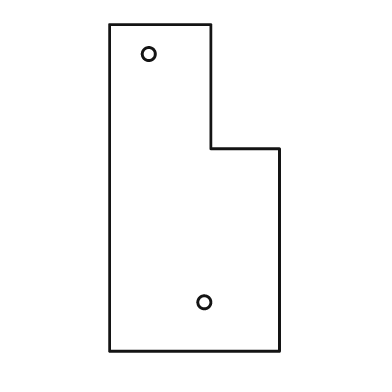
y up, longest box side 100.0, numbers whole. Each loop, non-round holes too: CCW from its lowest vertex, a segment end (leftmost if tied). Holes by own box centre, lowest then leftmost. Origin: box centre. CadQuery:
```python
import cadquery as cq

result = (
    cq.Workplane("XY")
    .moveTo(-26.0, -50.0)
    .lineTo(26.0, -50.0)
    .lineTo(26.0, 12.0)
    .lineTo(5.0, 12.0)
    .lineTo(5.0, 50.0)
    .lineTo(-26.0, 50.0)
    .close()
    .moveTo(3.0, -35.0)
    .circle(2.0)
    .moveTo(-14.0, 41.0)
    .circle(2.0)
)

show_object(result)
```